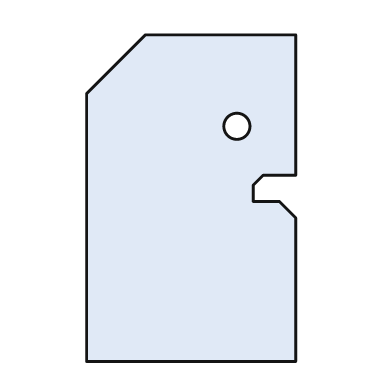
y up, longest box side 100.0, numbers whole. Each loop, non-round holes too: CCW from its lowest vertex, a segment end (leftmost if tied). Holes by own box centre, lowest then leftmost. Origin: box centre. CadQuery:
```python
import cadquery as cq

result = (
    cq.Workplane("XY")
    .moveTo(-32.0, -50.0)
    .lineTo(32.0, -50.0)
    .lineTo(32.0, -6.0)
    .lineTo(27.0, -1.0)
    .lineTo(19.0, -1.0)
    .lineTo(19.0, 4.0)
    .lineTo(22.0, 7.0)
    .lineTo(32.0, 7.0)
    .lineTo(32.0, 50.0)
    .lineTo(-14.0, 50.0)
    .lineTo(-32.0, 32.0)
    .close()
    .moveTo(14.0, 22.0)
    .circle(4.0)
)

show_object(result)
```